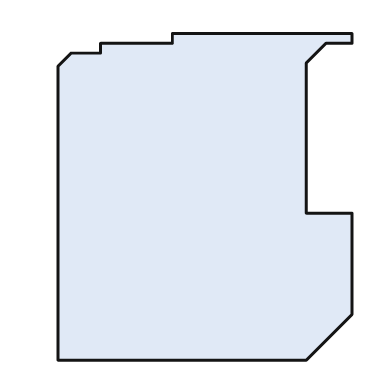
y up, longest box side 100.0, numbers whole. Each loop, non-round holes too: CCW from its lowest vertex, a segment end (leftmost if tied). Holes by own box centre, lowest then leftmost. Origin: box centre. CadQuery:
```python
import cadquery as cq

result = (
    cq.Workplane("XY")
    .moveTo(-45.0, -50.0)
    .lineTo(31.0, -50.0)
    .lineTo(45.0, -36.0)
    .lineTo(45.0, -5.0)
    .lineTo(31.0, -5.0)
    .lineTo(31.0, 41.0)
    .lineTo(37.0, 47.0)
    .lineTo(45.0, 47.0)
    .lineTo(45.0, 50.0)
    .lineTo(-10.0, 50.0)
    .lineTo(-10.0, 47.0)
    .lineTo(-32.0, 47.0)
    .lineTo(-32.0, 44.0)
    .lineTo(-41.0, 44.0)
    .lineTo(-45.0, 40.0)
    .close()
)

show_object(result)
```